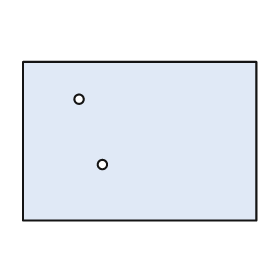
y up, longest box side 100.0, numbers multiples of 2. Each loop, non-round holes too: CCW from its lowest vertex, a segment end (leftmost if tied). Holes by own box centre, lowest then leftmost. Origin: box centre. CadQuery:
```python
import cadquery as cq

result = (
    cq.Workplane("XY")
    .moveTo(-50.0, -34.0)
    .lineTo(50.0, -34.0)
    .lineTo(50.0, 34.0)
    .lineTo(-50.0, 34.0)
    .close()
    .moveTo(-16.0, -10.0)
    .circle(2.0)
    .moveTo(-26.0, 18.0)
    .circle(2.0)
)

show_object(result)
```